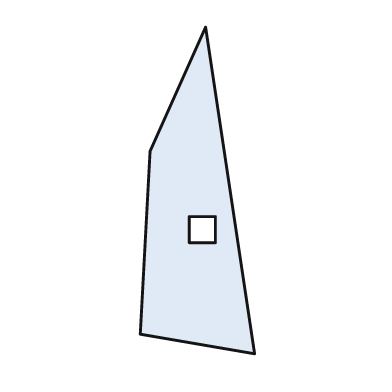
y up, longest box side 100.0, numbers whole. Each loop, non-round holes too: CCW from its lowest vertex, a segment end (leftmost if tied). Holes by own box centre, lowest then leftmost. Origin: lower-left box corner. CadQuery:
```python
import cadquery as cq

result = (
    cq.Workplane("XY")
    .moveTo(35.0, 0.0)
    .lineTo(20.0, 100.0)
    .lineTo(3.0, 62.0)
    .lineTo(0.0, 6.0)
    .close()
    .moveTo(15.0, 34.0)
    .lineTo(23.0, 34.0)
    .lineTo(23.0, 42.0)
    .lineTo(15.0, 42.0)
    .close()
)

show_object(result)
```